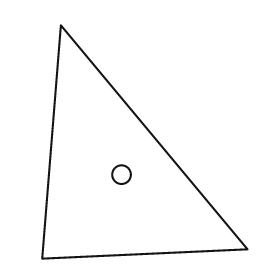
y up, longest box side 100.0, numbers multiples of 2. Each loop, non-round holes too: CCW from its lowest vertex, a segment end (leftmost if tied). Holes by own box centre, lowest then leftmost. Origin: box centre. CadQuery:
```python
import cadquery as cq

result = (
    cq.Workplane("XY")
    .moveTo(-44.0, -50.0)
    .lineTo(44.0, -46.0)
    .lineTo(-36.0, 50.0)
    .close()
    .moveTo(-10.0, -14.0)
    .circle(4.0)
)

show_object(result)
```